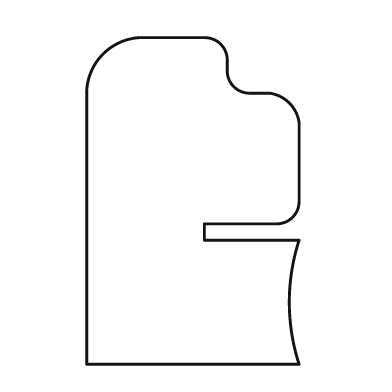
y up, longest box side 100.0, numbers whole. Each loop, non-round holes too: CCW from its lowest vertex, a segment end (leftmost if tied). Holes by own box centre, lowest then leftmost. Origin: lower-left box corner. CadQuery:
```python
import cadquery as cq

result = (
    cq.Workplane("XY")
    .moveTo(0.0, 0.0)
    .lineTo(65.0, 0.0)
    .threePointArc((62.0, 19.0), (65.0, 38.0))
    .lineTo(36.0, 38.0)
    .lineTo(36.0, 43.0)
    .lineTo(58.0, 43.0)
    .threePointArc((63.0, 45.0), (65.0, 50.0))
    .lineTo(65.0, 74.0)
    .threePointArc((62.0, 80.0), (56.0, 83.0))
    .lineTo(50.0, 83.0)
    .threePointArc((45.0, 85.0), (43.0, 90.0))
    .lineTo(43.0, 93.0)
    .threePointArc((41.0, 98.0), (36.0, 100.0))
    .lineTo(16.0, 100.0)
    .threePointArc((5.0, 95.0), (0.0, 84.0))
    .close()
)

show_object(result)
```